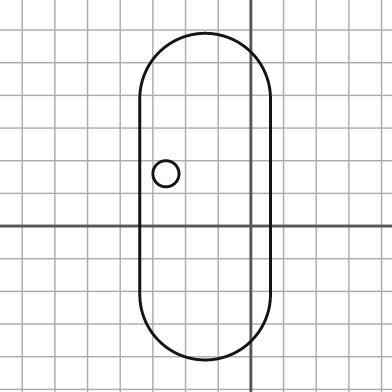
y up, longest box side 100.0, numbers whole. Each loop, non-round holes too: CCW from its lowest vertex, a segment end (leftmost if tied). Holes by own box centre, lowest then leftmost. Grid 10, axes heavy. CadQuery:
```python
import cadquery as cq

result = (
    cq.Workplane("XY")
    .moveTo(-34.0, -21.0)
    .threePointArc((-14.0, -41.0), (6.0, -21.0))
    .lineTo(6.0, 39.0)
    .threePointArc((-14.0, 59.0), (-34.0, 39.0))
    .close()
    .moveTo(-26.0, 16.0)
    .circle(4.0)
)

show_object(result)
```